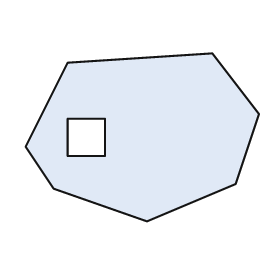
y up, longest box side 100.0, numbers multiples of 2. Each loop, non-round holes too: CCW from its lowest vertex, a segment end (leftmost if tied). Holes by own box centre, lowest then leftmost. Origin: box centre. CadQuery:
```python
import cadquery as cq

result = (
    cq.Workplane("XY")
    .moveTo(2.0, -36.0)
    .lineTo(40.0, -20.0)
    .lineTo(50.0, 10.0)
    .lineTo(30.0, 36.0)
    .lineTo(-32.0, 32.0)
    .lineTo(-50.0, -4.0)
    .lineTo(-38.0, -22.0)
    .close()
    .moveTo(-32.0, -8.0)
    .lineTo(-16.0, -8.0)
    .lineTo(-16.0, 8.0)
    .lineTo(-32.0, 8.0)
    .close()
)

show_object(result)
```